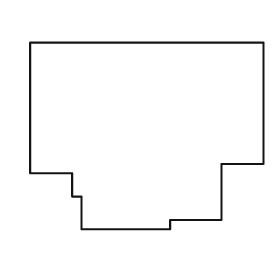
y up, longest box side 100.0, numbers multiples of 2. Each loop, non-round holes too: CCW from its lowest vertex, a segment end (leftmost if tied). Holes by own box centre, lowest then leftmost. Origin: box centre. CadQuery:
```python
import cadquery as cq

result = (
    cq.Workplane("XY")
    .moveTo(-28.0, -40.0)
    .lineTo(10.0, -40.0)
    .lineTo(10.0, -36.0)
    .lineTo(32.0, -36.0)
    .lineTo(32.0, -12.0)
    .lineTo(50.0, -12.0)
    .lineTo(50.0, 40.0)
    .lineTo(-50.0, 40.0)
    .lineTo(-50.0, -16.0)
    .lineTo(-32.0, -16.0)
    .lineTo(-32.0, -26.0)
    .lineTo(-28.0, -26.0)
    .close()
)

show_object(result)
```